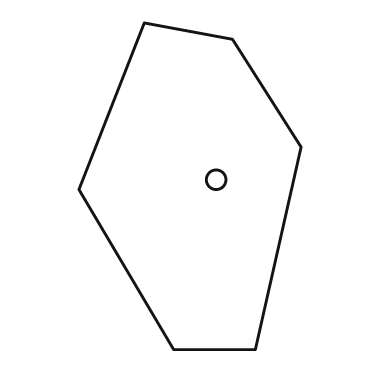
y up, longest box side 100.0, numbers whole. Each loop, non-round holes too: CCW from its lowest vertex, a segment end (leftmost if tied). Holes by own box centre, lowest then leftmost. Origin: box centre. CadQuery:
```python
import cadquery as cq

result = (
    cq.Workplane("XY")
    .moveTo(-5.0, -50.0)
    .lineTo(20.0, -50.0)
    .lineTo(34.0, 12.0)
    .lineTo(13.0, 45.0)
    .lineTo(-14.0, 50.0)
    .lineTo(-34.0, -1.0)
    .close()
    .moveTo(8.0, 2.0)
    .circle(3.0)
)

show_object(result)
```